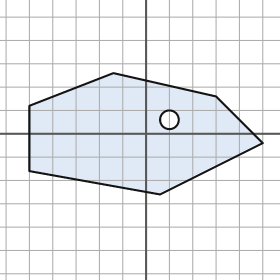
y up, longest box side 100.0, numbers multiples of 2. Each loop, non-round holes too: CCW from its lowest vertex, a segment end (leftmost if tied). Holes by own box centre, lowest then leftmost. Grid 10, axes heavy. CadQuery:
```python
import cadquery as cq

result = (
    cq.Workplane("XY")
    .moveTo(6.0, -26.0)
    .lineTo(50.0, -4.0)
    .lineTo(30.0, 16.0)
    .lineTo(-14.0, 26.0)
    .lineTo(-50.0, 12.0)
    .lineTo(-50.0, -16.0)
    .close()
    .moveTo(10.0, 6.0)
    .circle(4.0)
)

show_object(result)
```